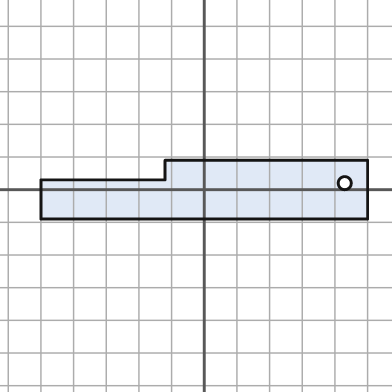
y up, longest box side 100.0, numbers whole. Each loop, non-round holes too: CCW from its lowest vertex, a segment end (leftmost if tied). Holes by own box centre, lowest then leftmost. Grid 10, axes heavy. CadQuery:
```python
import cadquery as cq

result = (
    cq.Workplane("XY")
    .moveTo(-50.0, -9.0)
    .lineTo(50.0, -9.0)
    .lineTo(50.0, 9.0)
    .lineTo(-12.0, 9.0)
    .lineTo(-12.0, 3.0)
    .lineTo(-50.0, 3.0)
    .close()
    .moveTo(43.0, 2.0)
    .circle(2.0)
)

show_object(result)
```